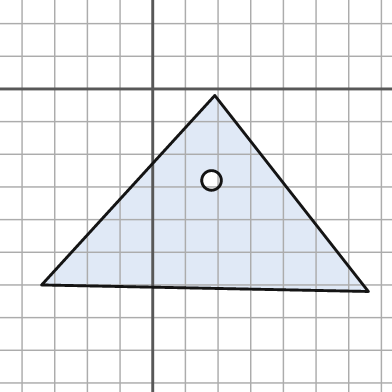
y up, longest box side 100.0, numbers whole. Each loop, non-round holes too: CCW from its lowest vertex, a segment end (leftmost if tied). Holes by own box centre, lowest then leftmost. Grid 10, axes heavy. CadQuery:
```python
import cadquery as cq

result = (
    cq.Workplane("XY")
    .moveTo(66.0, -62.0)
    .lineTo(19.0, -2.0)
    .lineTo(-34.0, -60.0)
    .close()
    .moveTo(18.0, -28.0)
    .circle(3.0)
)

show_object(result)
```